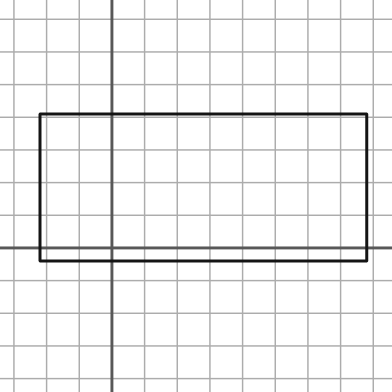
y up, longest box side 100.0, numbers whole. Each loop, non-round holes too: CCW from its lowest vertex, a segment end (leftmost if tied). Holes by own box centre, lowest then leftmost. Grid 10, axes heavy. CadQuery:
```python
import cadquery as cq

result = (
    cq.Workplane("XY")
    .moveTo(-22.0, -4.0)
    .lineTo(78.0, -4.0)
    .lineTo(78.0, 41.0)
    .lineTo(-22.0, 41.0)
    .close()
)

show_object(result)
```